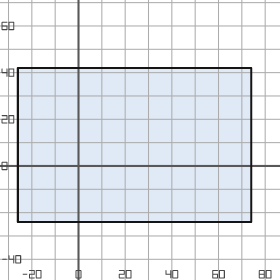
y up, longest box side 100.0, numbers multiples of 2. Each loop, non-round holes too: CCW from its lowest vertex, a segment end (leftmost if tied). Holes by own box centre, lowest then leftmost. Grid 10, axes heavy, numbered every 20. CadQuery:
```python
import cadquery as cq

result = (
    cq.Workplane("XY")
    .moveTo(-26.0, -24.0)
    .lineTo(74.0, -24.0)
    .lineTo(74.0, 42.0)
    .lineTo(-26.0, 42.0)
    .close()
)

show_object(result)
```